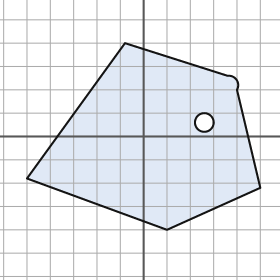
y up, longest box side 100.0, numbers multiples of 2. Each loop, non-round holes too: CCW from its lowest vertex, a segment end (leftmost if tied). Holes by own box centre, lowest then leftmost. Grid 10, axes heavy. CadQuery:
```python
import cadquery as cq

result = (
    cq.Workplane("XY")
    .moveTo(10.0, -40.0)
    .lineTo(50.0, -22.0)
    .lineTo(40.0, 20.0)
    .threePointArc((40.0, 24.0), (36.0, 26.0))
    .lineTo(-8.0, 40.0)
    .lineTo(-50.0, -18.0)
    .close()
    .moveTo(26.0, 6.0)
    .circle(4.0)
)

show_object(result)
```